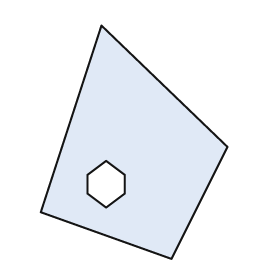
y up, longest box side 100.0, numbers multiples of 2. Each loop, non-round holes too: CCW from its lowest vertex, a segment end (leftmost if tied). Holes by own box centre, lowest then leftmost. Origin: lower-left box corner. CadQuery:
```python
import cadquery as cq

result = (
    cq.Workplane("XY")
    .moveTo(56.0, 0.0)
    .lineTo(80.0, 48.0)
    .lineTo(26.0, 100.0)
    .lineTo(0.0, 20.0)
    .close()
    .moveTo(28.0, 22.0)
    .lineTo(36.0, 28.0)
    .lineTo(36.0, 36.0)
    .lineTo(28.0, 42.0)
    .lineTo(20.0, 36.0)
    .lineTo(20.0, 28.0)
    .close()
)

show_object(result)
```